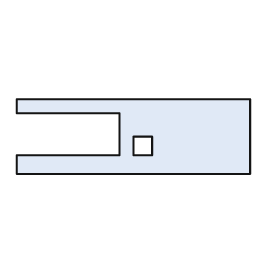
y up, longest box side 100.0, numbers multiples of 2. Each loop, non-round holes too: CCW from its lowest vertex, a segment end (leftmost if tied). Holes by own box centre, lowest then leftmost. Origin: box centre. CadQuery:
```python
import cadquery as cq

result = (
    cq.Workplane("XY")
    .moveTo(-50.0, -16.0)
    .lineTo(50.0, -16.0)
    .lineTo(50.0, 16.0)
    .lineTo(-50.0, 16.0)
    .lineTo(-50.0, 10.0)
    .lineTo(-6.0, 10.0)
    .lineTo(-6.0, -8.0)
    .lineTo(-50.0, -8.0)
    .close()
    .moveTo(0.0, -8.0)
    .lineTo(8.0, -8.0)
    .lineTo(8.0, 0.0)
    .lineTo(0.0, 0.0)
    .close()
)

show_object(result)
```